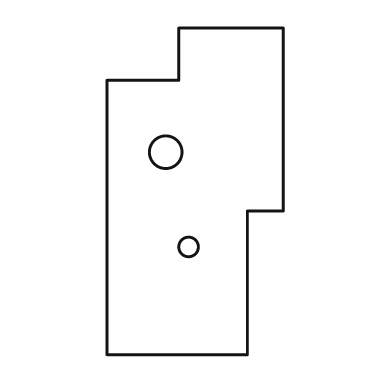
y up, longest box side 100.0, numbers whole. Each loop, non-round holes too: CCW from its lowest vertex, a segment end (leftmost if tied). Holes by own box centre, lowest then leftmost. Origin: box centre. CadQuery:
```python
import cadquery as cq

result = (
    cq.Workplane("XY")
    .moveTo(-27.0, -50.0)
    .lineTo(16.0, -50.0)
    .lineTo(16.0, -6.0)
    .lineTo(27.0, -6.0)
    .lineTo(27.0, 50.0)
    .lineTo(-5.0, 50.0)
    .lineTo(-5.0, 34.0)
    .lineTo(-27.0, 34.0)
    .close()
    .moveTo(-2.0, -17.0)
    .circle(3.0)
    .moveTo(-9.0, 12.0)
    .circle(5.0)
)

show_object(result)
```